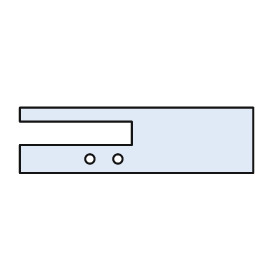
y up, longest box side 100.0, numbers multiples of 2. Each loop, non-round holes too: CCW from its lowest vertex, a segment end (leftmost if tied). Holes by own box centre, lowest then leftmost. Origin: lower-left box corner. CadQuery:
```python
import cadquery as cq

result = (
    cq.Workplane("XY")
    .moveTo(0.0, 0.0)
    .lineTo(100.0, 0.0)
    .lineTo(100.0, 28.0)
    .lineTo(0.0, 28.0)
    .lineTo(0.0, 22.0)
    .lineTo(48.0, 22.0)
    .lineTo(48.0, 12.0)
    .lineTo(0.0, 12.0)
    .close()
    .moveTo(30.0, 6.0)
    .circle(2.0)
    .moveTo(42.0, 6.0)
    .circle(2.0)
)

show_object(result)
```